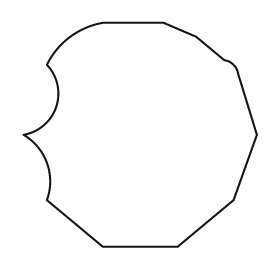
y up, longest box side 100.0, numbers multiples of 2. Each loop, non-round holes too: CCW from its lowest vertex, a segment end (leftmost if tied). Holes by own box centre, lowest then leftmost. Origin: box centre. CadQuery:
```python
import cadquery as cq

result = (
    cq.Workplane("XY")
    .moveTo(-16.0, -48.0)
    .lineTo(16.0, -48.0)
    .lineTo(40.0, -28.0)
    .lineTo(50.0, 0.0)
    .lineTo(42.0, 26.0)
    .threePointArc((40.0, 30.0), (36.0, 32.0))
    .lineTo(24.0, 42.0)
    .lineTo(10.0, 48.0)
    .lineTo(-16.0, 48.0)
    .threePointArc((-30.0, 42.0), (-40.0, 30.0))
    .threePointArc((-36.0, 12.0), (-50.0, 0.0))
    .threePointArc((-40.0, -12.0), (-40.0, -28.0))
    .close()
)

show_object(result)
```